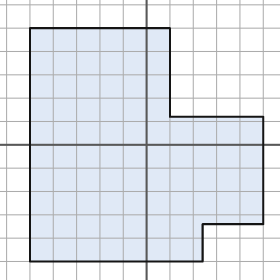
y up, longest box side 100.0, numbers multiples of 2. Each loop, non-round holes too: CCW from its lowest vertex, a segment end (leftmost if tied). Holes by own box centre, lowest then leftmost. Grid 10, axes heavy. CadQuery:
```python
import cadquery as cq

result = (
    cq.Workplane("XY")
    .moveTo(-50.0, -50.0)
    .lineTo(24.0, -50.0)
    .lineTo(24.0, -34.0)
    .lineTo(50.0, -34.0)
    .lineTo(50.0, 12.0)
    .lineTo(10.0, 12.0)
    .lineTo(10.0, 50.0)
    .lineTo(-50.0, 50.0)
    .close()
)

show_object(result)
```